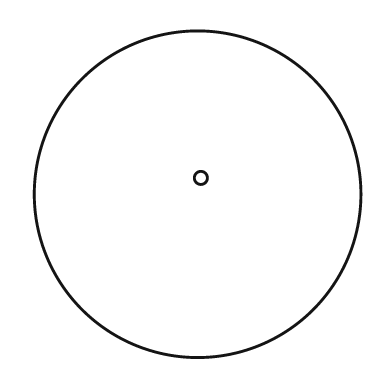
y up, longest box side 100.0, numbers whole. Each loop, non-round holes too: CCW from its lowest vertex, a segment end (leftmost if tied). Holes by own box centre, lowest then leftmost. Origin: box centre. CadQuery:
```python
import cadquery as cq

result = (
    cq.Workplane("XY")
    .moveTo(0.0, 0.0)
    .circle(50.0)
    .moveTo(1.0, 5.0)
    .circle(2.0)
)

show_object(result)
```